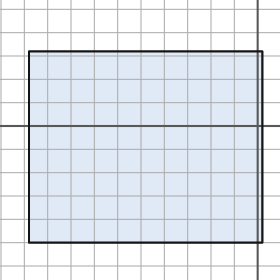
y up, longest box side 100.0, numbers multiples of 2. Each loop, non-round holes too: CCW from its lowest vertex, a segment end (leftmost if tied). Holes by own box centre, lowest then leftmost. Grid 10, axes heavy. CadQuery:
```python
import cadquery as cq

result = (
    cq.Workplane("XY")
    .moveTo(-98.0, -50.0)
    .lineTo(2.0, -50.0)
    .lineTo(2.0, 32.0)
    .lineTo(-98.0, 32.0)
    .close()
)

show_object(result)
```